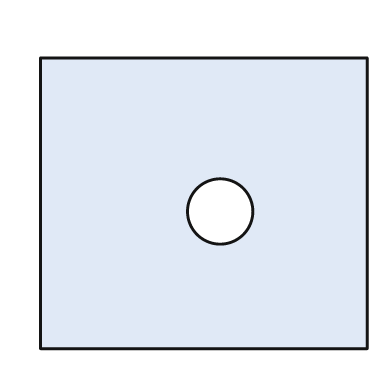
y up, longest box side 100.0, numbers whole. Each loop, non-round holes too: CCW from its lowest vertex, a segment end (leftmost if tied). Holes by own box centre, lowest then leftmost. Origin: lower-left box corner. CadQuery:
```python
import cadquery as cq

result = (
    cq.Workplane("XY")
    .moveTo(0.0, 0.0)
    .lineTo(100.0, 0.0)
    .lineTo(100.0, 89.0)
    .lineTo(0.0, 89.0)
    .close()
    .moveTo(55.0, 42.0)
    .circle(10.0)
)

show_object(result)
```